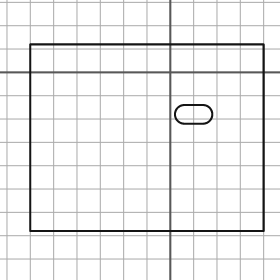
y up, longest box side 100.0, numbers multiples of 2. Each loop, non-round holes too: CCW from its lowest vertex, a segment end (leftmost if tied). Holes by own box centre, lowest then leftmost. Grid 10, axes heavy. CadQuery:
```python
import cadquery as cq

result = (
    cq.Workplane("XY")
    .moveTo(-60.0, -68.0)
    .lineTo(40.0, -68.0)
    .lineTo(40.0, 12.0)
    .lineTo(-60.0, 12.0)
    .close()
    .moveTo(6.0, -22.0)
    .lineTo(14.0, -22.0)
    .threePointArc((18.0, -18.0), (14.0, -14.0))
    .lineTo(6.0, -14.0)
    .threePointArc((2.0, -18.0), (6.0, -22.0))
    .close()
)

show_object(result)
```